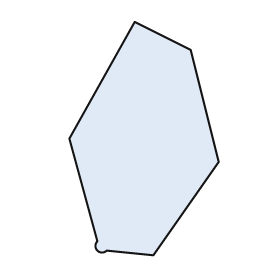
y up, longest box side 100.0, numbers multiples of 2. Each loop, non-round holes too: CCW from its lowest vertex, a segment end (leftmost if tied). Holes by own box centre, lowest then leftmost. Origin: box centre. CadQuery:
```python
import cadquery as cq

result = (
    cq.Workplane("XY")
    .moveTo(4.0, -50.0)
    .lineTo(32.0, -10.0)
    .lineTo(20.0, 38.0)
    .lineTo(-4.0, 50.0)
    .lineTo(-32.0, 0.0)
    .lineTo(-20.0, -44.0)
    .threePointArc((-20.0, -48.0), (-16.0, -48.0))
    .close()
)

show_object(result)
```